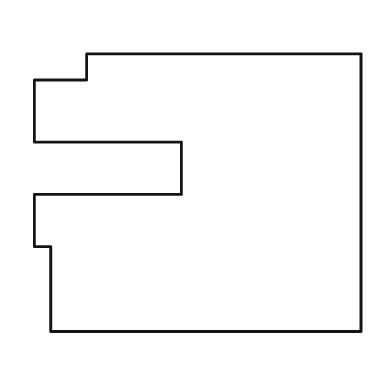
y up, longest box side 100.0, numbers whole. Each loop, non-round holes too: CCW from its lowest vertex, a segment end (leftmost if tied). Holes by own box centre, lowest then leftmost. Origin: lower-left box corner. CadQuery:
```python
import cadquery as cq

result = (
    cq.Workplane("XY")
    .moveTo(5.0, 0.0)
    .lineTo(100.0, 0.0)
    .lineTo(100.0, 85.0)
    .lineTo(16.0, 85.0)
    .lineTo(16.0, 77.0)
    .lineTo(0.0, 77.0)
    .lineTo(0.0, 58.0)
    .lineTo(45.0, 58.0)
    .lineTo(45.0, 42.0)
    .lineTo(0.0, 42.0)
    .lineTo(0.0, 26.0)
    .lineTo(5.0, 26.0)
    .close()
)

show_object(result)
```